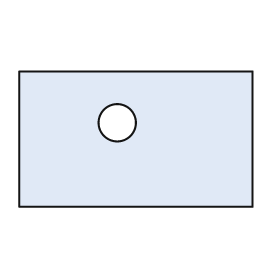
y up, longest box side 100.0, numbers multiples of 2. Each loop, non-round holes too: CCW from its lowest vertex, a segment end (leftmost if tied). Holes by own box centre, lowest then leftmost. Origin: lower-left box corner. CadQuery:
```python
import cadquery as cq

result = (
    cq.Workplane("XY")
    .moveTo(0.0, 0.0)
    .lineTo(100.0, 0.0)
    .lineTo(100.0, 58.0)
    .lineTo(0.0, 58.0)
    .close()
    .moveTo(42.0, 36.0)
    .circle(8.0)
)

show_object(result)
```